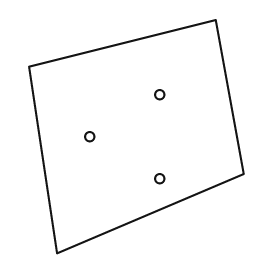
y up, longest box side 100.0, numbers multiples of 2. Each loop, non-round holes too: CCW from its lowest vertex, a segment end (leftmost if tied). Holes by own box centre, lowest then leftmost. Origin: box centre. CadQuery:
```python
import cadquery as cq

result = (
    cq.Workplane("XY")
    .moveTo(-34.0, -50.0)
    .lineTo(46.0, -16.0)
    .lineTo(34.0, 50.0)
    .lineTo(-46.0, 30.0)
    .close()
    .moveTo(10.0, -18.0)
    .circle(2.0)
    .moveTo(-20.0, 0.0)
    .circle(2.0)
    .moveTo(10.0, 18.0)
    .circle(2.0)
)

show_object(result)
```